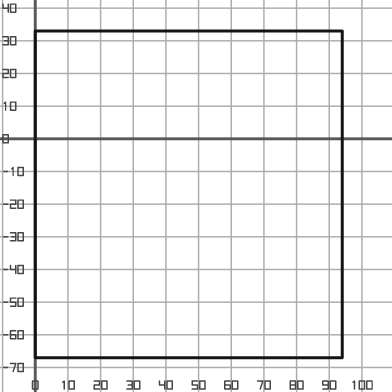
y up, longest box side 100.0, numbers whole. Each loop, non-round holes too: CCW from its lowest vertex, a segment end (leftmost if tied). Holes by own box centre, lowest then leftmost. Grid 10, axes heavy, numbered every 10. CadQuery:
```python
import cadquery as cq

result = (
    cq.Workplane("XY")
    .moveTo(0.0, -67.0)
    .lineTo(94.0, -67.0)
    .lineTo(94.0, 33.0)
    .lineTo(0.0, 33.0)
    .close()
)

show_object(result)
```